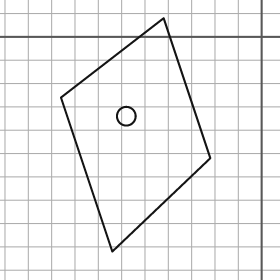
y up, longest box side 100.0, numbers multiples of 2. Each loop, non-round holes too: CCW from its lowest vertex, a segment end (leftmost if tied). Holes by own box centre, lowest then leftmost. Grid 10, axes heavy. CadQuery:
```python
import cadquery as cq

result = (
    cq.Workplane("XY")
    .moveTo(-64.0, -92.0)
    .lineTo(-22.0, -52.0)
    .lineTo(-42.0, 8.0)
    .lineTo(-86.0, -26.0)
    .close()
    .moveTo(-58.0, -34.0)
    .circle(4.0)
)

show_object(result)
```